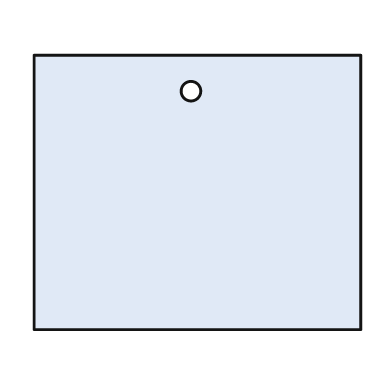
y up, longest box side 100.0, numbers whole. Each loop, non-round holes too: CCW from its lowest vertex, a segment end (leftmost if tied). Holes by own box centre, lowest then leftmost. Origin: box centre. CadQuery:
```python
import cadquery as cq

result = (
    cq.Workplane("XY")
    .moveTo(-50.0, -42.0)
    .lineTo(50.0, -42.0)
    .lineTo(50.0, 42.0)
    .lineTo(-50.0, 42.0)
    .close()
    .moveTo(-2.0, 31.0)
    .circle(3.0)
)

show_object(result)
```